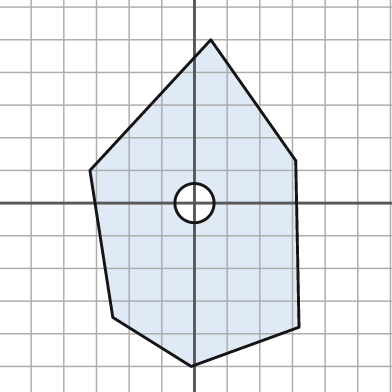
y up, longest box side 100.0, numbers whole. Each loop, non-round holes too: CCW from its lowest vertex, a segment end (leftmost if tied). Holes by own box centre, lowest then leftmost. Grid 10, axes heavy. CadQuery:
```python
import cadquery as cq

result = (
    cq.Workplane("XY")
    .moveTo(-1.0, -50.0)
    .lineTo(32.0, -38.0)
    .lineTo(31.0, 13.0)
    .lineTo(5.0, 50.0)
    .lineTo(-32.0, 10.0)
    .lineTo(-25.0, -35.0)
    .close()
    .moveTo(0.0, 0.0)
    .circle(6.0)
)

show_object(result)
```